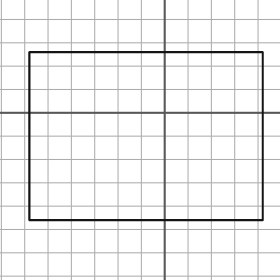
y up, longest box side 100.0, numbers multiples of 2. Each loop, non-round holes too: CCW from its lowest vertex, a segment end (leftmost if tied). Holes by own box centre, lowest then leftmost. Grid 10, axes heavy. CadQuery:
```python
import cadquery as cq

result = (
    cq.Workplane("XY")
    .moveTo(-58.0, -46.0)
    .lineTo(42.0, -46.0)
    .lineTo(42.0, 26.0)
    .lineTo(-58.0, 26.0)
    .close()
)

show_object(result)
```